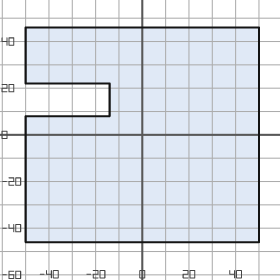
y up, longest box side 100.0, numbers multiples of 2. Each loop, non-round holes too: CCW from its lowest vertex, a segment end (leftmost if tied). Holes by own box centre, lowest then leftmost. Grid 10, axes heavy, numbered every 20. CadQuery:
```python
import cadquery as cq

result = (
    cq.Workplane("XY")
    .moveTo(-50.0, -46.0)
    .lineTo(50.0, -46.0)
    .lineTo(50.0, 46.0)
    .lineTo(-50.0, 46.0)
    .lineTo(-50.0, 22.0)
    .lineTo(-14.0, 22.0)
    .lineTo(-14.0, 8.0)
    .lineTo(-50.0, 8.0)
    .close()
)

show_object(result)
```